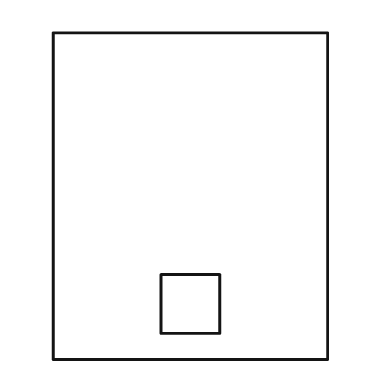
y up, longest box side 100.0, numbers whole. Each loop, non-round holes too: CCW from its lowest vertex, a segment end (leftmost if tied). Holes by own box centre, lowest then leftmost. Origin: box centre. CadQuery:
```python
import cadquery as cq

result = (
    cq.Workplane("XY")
    .moveTo(-42.0, -50.0)
    .lineTo(42.0, -50.0)
    .lineTo(42.0, 50.0)
    .lineTo(-42.0, 50.0)
    .close()
    .moveTo(-9.0, -42.0)
    .lineTo(9.0, -42.0)
    .lineTo(9.0, -24.0)
    .lineTo(-9.0, -24.0)
    .close()
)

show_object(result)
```